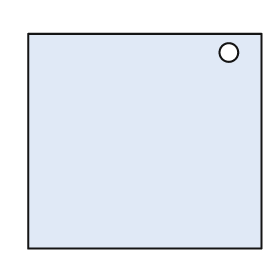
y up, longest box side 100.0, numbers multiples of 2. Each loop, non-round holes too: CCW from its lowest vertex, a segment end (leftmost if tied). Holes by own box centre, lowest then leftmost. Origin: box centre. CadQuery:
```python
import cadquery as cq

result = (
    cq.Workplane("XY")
    .moveTo(-50.0, -46.0)
    .lineTo(50.0, -46.0)
    .lineTo(50.0, 46.0)
    .lineTo(-50.0, 46.0)
    .close()
    .moveTo(36.0, 38.0)
    .circle(4.0)
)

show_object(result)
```